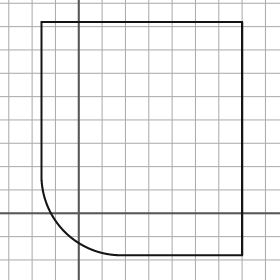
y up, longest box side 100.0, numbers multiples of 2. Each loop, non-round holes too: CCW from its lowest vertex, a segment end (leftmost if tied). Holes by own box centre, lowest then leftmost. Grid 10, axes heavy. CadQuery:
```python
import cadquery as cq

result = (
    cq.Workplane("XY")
    .moveTo(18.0, -18.0)
    .lineTo(70.0, -18.0)
    .lineTo(70.0, 82.0)
    .lineTo(-16.0, 82.0)
    .lineTo(-16.0, 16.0)
    .threePointArc((-6.0, -8.0), (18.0, -18.0))
    .close()
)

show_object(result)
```